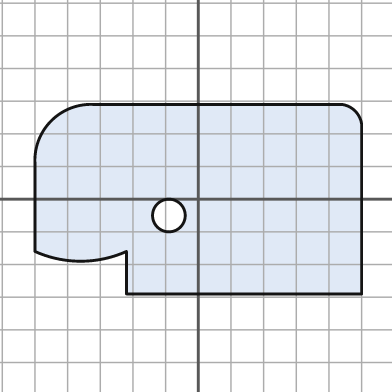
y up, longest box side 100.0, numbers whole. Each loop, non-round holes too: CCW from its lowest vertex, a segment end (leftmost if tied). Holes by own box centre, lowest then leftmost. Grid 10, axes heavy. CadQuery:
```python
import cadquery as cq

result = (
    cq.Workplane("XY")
    .moveTo(-22.0, -29.0)
    .lineTo(50.0, -29.0)
    .lineTo(50.0, 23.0)
    .threePointArc((48.0, 27.0), (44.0, 29.0))
    .lineTo(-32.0, 29.0)
    .threePointArc((-45.0, 24.0), (-50.0, 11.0))
    .lineTo(-50.0, -16.0)
    .threePointArc((-36.0, -19.0), (-22.0, -16.0))
    .close()
    .moveTo(-9.0, -5.0)
    .circle(5.0)
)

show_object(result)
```